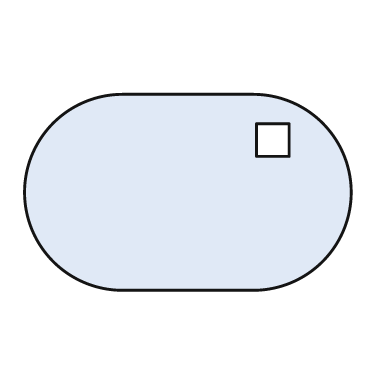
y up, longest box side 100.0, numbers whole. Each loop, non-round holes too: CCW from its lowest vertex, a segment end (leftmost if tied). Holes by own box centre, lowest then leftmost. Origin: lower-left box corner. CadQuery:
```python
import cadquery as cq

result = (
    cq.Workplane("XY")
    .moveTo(30.0, 0.0)
    .lineTo(70.0, 0.0)
    .threePointArc((100.0, 30.0), (70.0, 60.0))
    .lineTo(30.0, 60.0)
    .threePointArc((0.0, 30.0), (30.0, 0.0))
    .close()
    .moveTo(71.0, 41.0)
    .lineTo(81.0, 41.0)
    .lineTo(81.0, 51.0)
    .lineTo(71.0, 51.0)
    .close()
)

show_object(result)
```